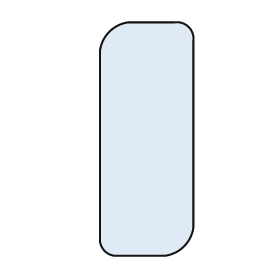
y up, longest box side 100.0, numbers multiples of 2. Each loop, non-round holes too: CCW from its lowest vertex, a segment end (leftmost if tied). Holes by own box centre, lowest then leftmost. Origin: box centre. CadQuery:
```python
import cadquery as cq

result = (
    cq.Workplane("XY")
    .moveTo(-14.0, -50.0)
    .lineTo(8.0, -50.0)
    .threePointArc((16.0, -46.0), (20.0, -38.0))
    .lineTo(20.0, 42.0)
    .threePointArc((18.0, 48.0), (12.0, 50.0))
    .lineTo(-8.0, 50.0)
    .threePointArc((-16.0, 46.0), (-20.0, 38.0))
    .lineTo(-20.0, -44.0)
    .threePointArc((-18.0, -48.0), (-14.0, -50.0))
    .close()
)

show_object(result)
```